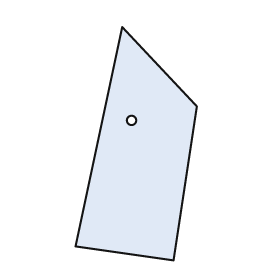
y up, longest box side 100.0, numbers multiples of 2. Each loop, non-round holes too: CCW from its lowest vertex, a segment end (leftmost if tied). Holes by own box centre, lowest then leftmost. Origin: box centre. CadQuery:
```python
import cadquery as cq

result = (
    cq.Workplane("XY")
    .moveTo(16.0, -50.0)
    .lineTo(26.0, 16.0)
    .lineTo(-6.0, 50.0)
    .lineTo(-26.0, -44.0)
    .close()
    .moveTo(-2.0, 10.0)
    .circle(2.0)
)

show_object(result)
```